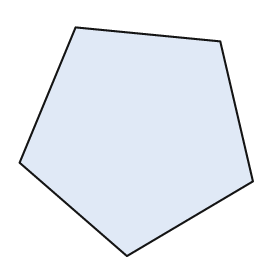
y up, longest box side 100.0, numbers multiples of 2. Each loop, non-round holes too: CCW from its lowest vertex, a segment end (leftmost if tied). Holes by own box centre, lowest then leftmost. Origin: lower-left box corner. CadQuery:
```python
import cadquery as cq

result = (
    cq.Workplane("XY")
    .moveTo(46.0, 0.0)
    .lineTo(100.0, 32.0)
    .lineTo(86.0, 92.0)
    .lineTo(24.0, 98.0)
    .lineTo(0.0, 40.0)
    .close()
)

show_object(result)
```